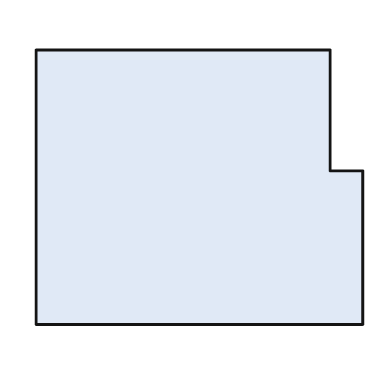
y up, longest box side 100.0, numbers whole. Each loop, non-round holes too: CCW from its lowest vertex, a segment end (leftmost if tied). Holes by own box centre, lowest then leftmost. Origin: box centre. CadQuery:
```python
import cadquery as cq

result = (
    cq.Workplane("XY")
    .moveTo(-50.0, -42.0)
    .lineTo(50.0, -42.0)
    .lineTo(50.0, 5.0)
    .lineTo(40.0, 5.0)
    .lineTo(40.0, 42.0)
    .lineTo(-50.0, 42.0)
    .close()
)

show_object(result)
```